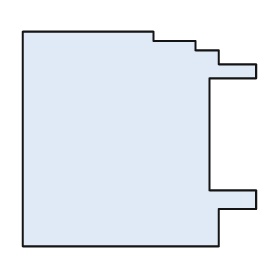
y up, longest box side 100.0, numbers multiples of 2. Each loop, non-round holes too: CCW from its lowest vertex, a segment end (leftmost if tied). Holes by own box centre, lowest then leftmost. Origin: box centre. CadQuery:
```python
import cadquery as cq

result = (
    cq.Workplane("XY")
    .moveTo(-50.0, -46.0)
    .lineTo(34.0, -46.0)
    .lineTo(34.0, -30.0)
    .lineTo(50.0, -30.0)
    .lineTo(50.0, -22.0)
    .lineTo(30.0, -22.0)
    .lineTo(30.0, 26.0)
    .lineTo(50.0, 26.0)
    .lineTo(50.0, 32.0)
    .lineTo(34.0, 32.0)
    .lineTo(34.0, 38.0)
    .lineTo(24.0, 38.0)
    .lineTo(24.0, 42.0)
    .lineTo(6.0, 42.0)
    .lineTo(6.0, 46.0)
    .lineTo(-50.0, 46.0)
    .close()
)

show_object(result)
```